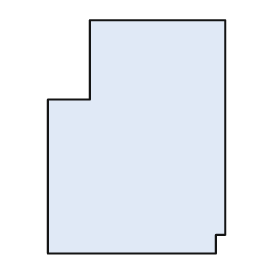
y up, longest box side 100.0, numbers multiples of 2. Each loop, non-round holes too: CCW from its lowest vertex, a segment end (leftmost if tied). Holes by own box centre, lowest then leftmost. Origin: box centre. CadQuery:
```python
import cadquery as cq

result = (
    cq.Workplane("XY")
    .moveTo(-38.0, -50.0)
    .lineTo(34.0, -50.0)
    .lineTo(34.0, -42.0)
    .lineTo(38.0, -42.0)
    .lineTo(38.0, 50.0)
    .lineTo(-20.0, 50.0)
    .lineTo(-20.0, 16.0)
    .lineTo(-38.0, 16.0)
    .close()
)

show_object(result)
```